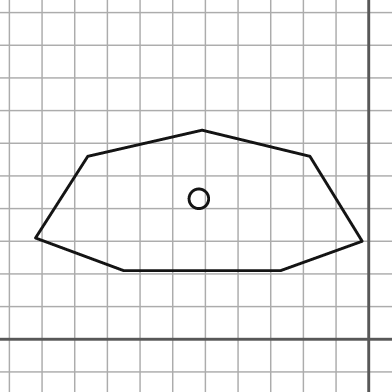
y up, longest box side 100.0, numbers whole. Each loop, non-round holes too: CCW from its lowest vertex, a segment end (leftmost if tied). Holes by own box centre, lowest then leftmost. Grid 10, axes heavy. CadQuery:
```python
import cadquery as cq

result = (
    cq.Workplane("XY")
    .moveTo(-75.0, 21.0)
    .lineTo(-27.0, 21.0)
    .lineTo(-2.0, 30.0)
    .lineTo(-18.0, 56.0)
    .lineTo(-51.0, 64.0)
    .lineTo(-86.0, 56.0)
    .lineTo(-102.0, 31.0)
    .close()
    .moveTo(-52.0, 43.0)
    .circle(3.0)
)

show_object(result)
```